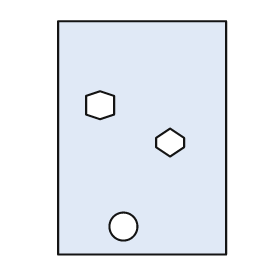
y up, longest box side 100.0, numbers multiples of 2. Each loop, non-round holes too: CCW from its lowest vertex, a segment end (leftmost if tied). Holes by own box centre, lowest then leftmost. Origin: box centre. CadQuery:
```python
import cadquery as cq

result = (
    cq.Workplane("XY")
    .moveTo(-36.0, -50.0)
    .lineTo(36.0, -50.0)
    .lineTo(36.0, 50.0)
    .lineTo(-36.0, 50.0)
    .close()
    .moveTo(-8.0, -38.0)
    .circle(6.0)
    .moveTo(12.0, -8.0)
    .lineTo(18.0, -4.0)
    .lineTo(18.0, 0.0)
    .lineTo(12.0, 4.0)
    .lineTo(6.0, 0.0)
    .lineTo(6.0, -4.0)
    .close()
    .moveTo(-18.0, 8.0)
    .lineTo(-12.0, 10.0)
    .lineTo(-12.0, 18.0)
    .lineTo(-18.0, 20.0)
    .lineTo(-24.0, 18.0)
    .lineTo(-24.0, 10.0)
    .close()
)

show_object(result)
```